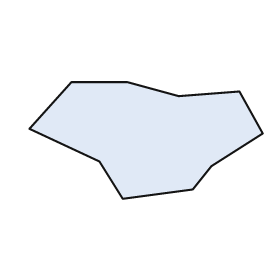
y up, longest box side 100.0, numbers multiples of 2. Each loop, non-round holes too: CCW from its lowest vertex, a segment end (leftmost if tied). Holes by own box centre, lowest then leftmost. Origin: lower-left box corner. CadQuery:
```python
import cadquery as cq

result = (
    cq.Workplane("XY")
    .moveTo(40.0, 0.0)
    .lineTo(70.0, 4.0)
    .lineTo(78.0, 14.0)
    .lineTo(100.0, 28.0)
    .lineTo(90.0, 46.0)
    .lineTo(64.0, 44.0)
    .lineTo(42.0, 50.0)
    .lineTo(18.0, 50.0)
    .lineTo(0.0, 30.0)
    .lineTo(30.0, 16.0)
    .close()
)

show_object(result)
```